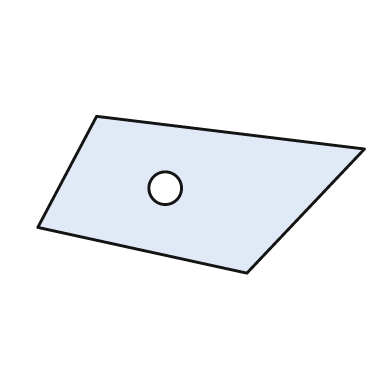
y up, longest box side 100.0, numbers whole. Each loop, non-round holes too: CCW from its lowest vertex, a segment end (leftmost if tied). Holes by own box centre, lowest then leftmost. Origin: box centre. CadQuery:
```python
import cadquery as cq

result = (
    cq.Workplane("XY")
    .moveTo(14.0, -24.0)
    .lineTo(50.0, 14.0)
    .lineTo(-32.0, 24.0)
    .lineTo(-50.0, -10.0)
    .close()
    .moveTo(-11.0, 2.0)
    .circle(5.0)
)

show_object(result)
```